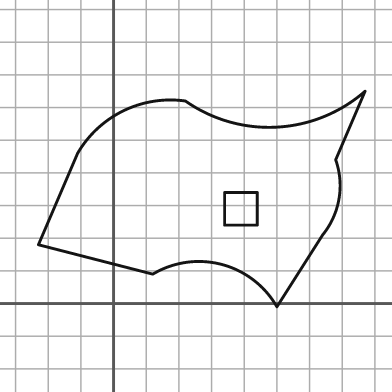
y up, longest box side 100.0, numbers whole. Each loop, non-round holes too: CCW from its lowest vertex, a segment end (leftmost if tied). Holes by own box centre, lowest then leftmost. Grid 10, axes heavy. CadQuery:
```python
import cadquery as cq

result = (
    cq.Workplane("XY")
    .moveTo(50.0, -1.0)
    .lineTo(64.0, 21.0)
    .threePointArc((69.0, 32.0), (68.0, 44.0))
    .lineTo(77.0, 65.0)
    .threePointArc((50.0, 54.0), (22.0, 62.0))
    .threePointArc((3.0, 59.0), (-11.0, 46.0))
    .lineTo(-23.0, 18.0)
    .lineTo(12.0, 9.0)
    .threePointArc((33.0, 12.0), (50.0, -1.0))
    .close()
    .moveTo(34.0, 24.0)
    .lineTo(44.0, 24.0)
    .lineTo(44.0, 34.0)
    .lineTo(34.0, 34.0)
    .close()
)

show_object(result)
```